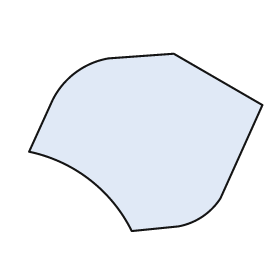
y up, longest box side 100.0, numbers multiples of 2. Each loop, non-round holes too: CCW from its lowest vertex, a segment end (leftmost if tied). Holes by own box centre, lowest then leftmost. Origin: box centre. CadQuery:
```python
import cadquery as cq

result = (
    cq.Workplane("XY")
    .moveTo(-6.0, -38.0)
    .lineTo(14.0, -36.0)
    .threePointArc((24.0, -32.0), (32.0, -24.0))
    .lineTo(50.0, 16.0)
    .lineTo(12.0, 38.0)
    .lineTo(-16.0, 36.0)
    .threePointArc((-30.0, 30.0), (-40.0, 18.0))
    .lineTo(-50.0, -4.0)
    .threePointArc((-24.0, -16.0), (-6.0, -38.0))
    .close()
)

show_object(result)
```